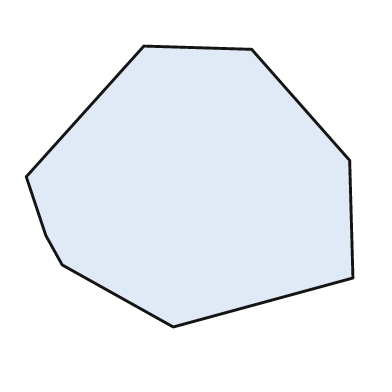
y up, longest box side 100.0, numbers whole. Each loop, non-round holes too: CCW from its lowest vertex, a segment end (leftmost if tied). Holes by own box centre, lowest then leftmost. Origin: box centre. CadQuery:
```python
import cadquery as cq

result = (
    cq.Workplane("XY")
    .moveTo(-5.0, -43.0)
    .lineTo(50.0, -28.0)
    .lineTo(49.0, 8.0)
    .lineTo(19.0, 42.0)
    .lineTo(-14.0, 43.0)
    .lineTo(-50.0, 3.0)
    .lineTo(-44.0, -15.0)
    .lineTo(-39.0, -24.0)
    .close()
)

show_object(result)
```